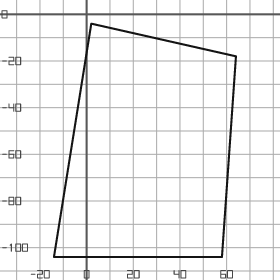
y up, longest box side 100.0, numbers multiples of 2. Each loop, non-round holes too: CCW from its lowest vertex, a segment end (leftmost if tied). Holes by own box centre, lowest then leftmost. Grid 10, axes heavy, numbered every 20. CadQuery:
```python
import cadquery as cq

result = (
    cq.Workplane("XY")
    .moveTo(-14.0, -104.0)
    .lineTo(58.0, -104.0)
    .lineTo(64.0, -18.0)
    .lineTo(2.0, -4.0)
    .close()
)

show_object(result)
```